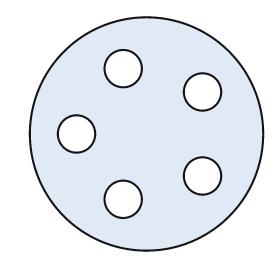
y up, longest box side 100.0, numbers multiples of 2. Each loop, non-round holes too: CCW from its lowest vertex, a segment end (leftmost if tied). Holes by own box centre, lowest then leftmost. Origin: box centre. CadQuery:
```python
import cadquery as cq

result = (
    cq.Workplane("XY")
    .moveTo(0.0, 0.0)
    .circle(50.0)
    .moveTo(-10.0, -28.0)
    .circle(8.0)
    .moveTo(24.0, -18.0)
    .circle(8.0)
    .moveTo(-30.0, 0.0)
    .circle(8.0)
    .moveTo(24.0, 18.0)
    .circle(8.0)
    .moveTo(-10.0, 28.0)
    .circle(8.0)
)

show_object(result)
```